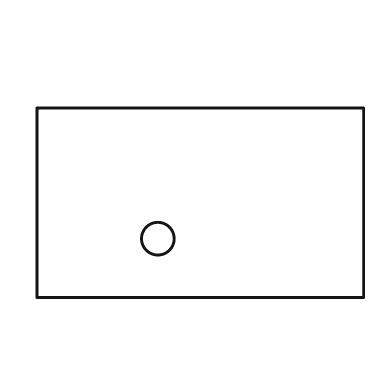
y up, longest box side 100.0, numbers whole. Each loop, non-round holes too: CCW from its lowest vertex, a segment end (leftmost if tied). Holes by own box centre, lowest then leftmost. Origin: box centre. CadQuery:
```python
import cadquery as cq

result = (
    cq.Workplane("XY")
    .moveTo(-50.0, -29.0)
    .lineTo(50.0, -29.0)
    .lineTo(50.0, 29.0)
    .lineTo(-50.0, 29.0)
    .close()
    .moveTo(-13.0, -11.0)
    .circle(5.0)
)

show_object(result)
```